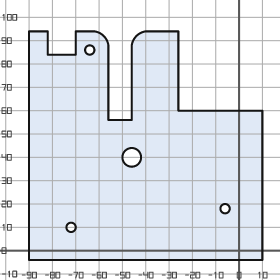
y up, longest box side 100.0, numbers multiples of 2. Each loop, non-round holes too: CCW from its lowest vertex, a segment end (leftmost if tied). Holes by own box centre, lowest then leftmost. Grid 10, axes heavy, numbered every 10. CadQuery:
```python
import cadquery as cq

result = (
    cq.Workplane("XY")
    .moveTo(-90.0, -4.0)
    .lineTo(10.0, -4.0)
    .lineTo(10.0, 60.0)
    .lineTo(-26.0, 60.0)
    .lineTo(-26.0, 94.0)
    .lineTo(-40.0, 94.0)
    .threePointArc((-44.0, 92.0), (-46.0, 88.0))
    .lineTo(-46.0, 56.0)
    .lineTo(-56.0, 56.0)
    .lineTo(-56.0, 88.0)
    .threePointArc((-58.0, 92.0), (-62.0, 94.0))
    .lineTo(-70.0, 94.0)
    .lineTo(-70.0, 84.0)
    .lineTo(-82.0, 84.0)
    .lineTo(-82.0, 94.0)
    .lineTo(-90.0, 94.0)
    .close()
    .moveTo(-72.0, 10.0)
    .circle(2.0)
    .moveTo(-6.0, 18.0)
    .circle(2.0)
    .moveTo(-46.0, 40.0)
    .circle(4.0)
    .moveTo(-64.0, 86.0)
    .circle(2.0)
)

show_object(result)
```